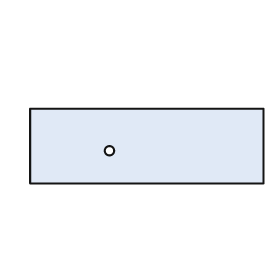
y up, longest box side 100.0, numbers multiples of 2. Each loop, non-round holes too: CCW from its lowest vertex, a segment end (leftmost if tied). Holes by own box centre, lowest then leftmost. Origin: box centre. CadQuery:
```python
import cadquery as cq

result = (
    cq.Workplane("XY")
    .moveTo(-50.0, -16.0)
    .lineTo(50.0, -16.0)
    .lineTo(50.0, 16.0)
    .lineTo(-50.0, 16.0)
    .close()
    .moveTo(-16.0, -2.0)
    .circle(2.0)
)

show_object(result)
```